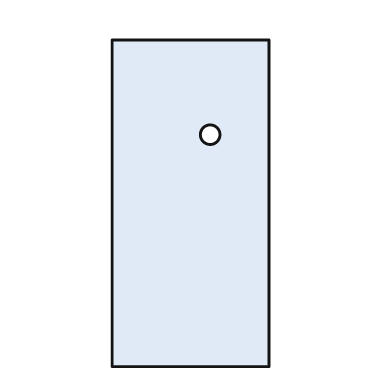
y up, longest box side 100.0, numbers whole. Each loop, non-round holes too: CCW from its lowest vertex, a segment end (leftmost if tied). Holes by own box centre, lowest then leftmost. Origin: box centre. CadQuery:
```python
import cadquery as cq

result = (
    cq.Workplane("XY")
    .moveTo(-24.0, -50.0)
    .lineTo(24.0, -50.0)
    .lineTo(24.0, 50.0)
    .lineTo(-24.0, 50.0)
    .close()
    .moveTo(6.0, 21.0)
    .circle(3.0)
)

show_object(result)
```